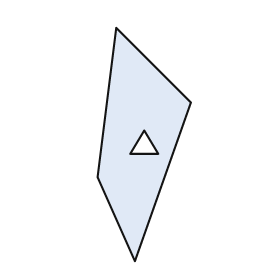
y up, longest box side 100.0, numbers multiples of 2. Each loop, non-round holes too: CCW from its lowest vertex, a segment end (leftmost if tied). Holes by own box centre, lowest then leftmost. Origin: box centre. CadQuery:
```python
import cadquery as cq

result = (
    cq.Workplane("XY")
    .moveTo(-4.0, -50.0)
    .lineTo(20.0, 18.0)
    .lineTo(-12.0, 50.0)
    .lineTo(-20.0, -14.0)
    .close()
    .moveTo(-6.0, -4.0)
    .lineTo(6.0, -4.0)
    .lineTo(0.0, 6.0)
    .close()
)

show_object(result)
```